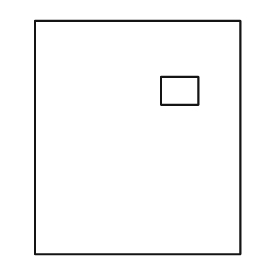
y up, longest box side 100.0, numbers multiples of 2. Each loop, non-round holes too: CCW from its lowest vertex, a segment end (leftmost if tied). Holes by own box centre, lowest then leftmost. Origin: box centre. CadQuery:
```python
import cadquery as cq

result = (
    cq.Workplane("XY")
    .moveTo(-44.0, -50.0)
    .lineTo(44.0, -50.0)
    .lineTo(44.0, 50.0)
    .lineTo(-44.0, 50.0)
    .close()
    .moveTo(10.0, 14.0)
    .lineTo(26.0, 14.0)
    .lineTo(26.0, 26.0)
    .lineTo(10.0, 26.0)
    .close()
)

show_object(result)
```